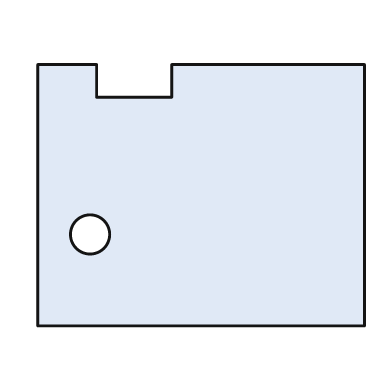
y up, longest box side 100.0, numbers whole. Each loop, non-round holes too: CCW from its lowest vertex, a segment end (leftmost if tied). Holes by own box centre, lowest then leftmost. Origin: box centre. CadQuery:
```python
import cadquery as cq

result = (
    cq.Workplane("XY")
    .moveTo(-50.0, -40.0)
    .lineTo(50.0, -40.0)
    .lineTo(50.0, 40.0)
    .lineTo(-9.0, 40.0)
    .lineTo(-9.0, 30.0)
    .lineTo(-32.0, 30.0)
    .lineTo(-32.0, 40.0)
    .lineTo(-50.0, 40.0)
    .close()
    .moveTo(-34.0, -12.0)
    .circle(6.0)
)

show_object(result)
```